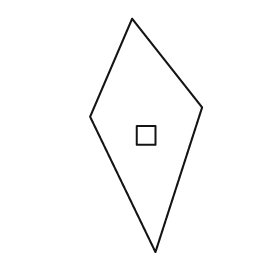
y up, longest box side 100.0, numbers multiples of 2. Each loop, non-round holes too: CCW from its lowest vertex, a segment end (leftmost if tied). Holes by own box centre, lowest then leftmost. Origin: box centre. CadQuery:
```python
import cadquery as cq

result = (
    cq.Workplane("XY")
    .moveTo(4.0, -50.0)
    .lineTo(24.0, 12.0)
    .lineTo(-6.0, 50.0)
    .lineTo(-24.0, 8.0)
    .close()
    .moveTo(-4.0, -4.0)
    .lineTo(4.0, -4.0)
    .lineTo(4.0, 4.0)
    .lineTo(-4.0, 4.0)
    .close()
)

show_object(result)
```